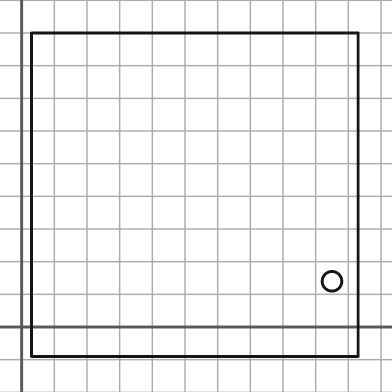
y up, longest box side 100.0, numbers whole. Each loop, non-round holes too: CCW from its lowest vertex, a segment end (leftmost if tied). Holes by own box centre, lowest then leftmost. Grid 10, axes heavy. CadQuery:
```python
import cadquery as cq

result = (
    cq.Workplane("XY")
    .moveTo(3.0, -9.0)
    .lineTo(103.0, -9.0)
    .lineTo(103.0, 90.0)
    .lineTo(3.0, 90.0)
    .close()
    .moveTo(95.0, 14.0)
    .circle(3.0)
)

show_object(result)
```